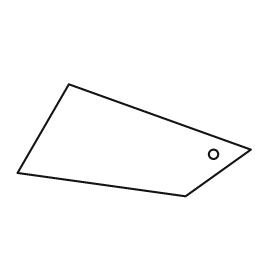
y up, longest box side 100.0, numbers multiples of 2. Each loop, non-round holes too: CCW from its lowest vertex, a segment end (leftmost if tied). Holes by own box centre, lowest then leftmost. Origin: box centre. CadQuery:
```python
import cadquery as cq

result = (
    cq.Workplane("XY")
    .moveTo(22.0, -24.0)
    .lineTo(50.0, -4.0)
    .lineTo(-28.0, 24.0)
    .lineTo(-50.0, -14.0)
    .close()
    .moveTo(34.0, -6.0)
    .circle(2.0)
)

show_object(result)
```